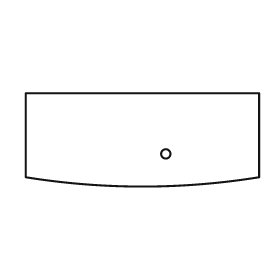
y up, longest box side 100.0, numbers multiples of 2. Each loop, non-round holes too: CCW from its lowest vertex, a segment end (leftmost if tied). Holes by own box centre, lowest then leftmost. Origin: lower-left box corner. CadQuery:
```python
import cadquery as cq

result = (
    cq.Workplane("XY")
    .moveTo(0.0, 4.0)
    .threePointArc((50.0, 0.0), (100.0, 4.0))
    .lineTo(100.0, 40.0)
    .lineTo(0.0, 40.0)
    .close()
    .moveTo(60.0, 14.0)
    .circle(2.0)
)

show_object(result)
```